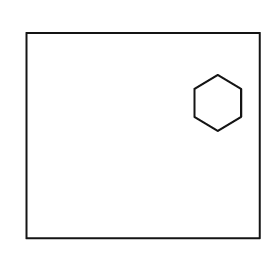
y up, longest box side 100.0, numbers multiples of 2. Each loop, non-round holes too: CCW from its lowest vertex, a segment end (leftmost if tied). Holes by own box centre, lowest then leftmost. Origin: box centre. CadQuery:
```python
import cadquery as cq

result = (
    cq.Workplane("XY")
    .moveTo(-50.0, -44.0)
    .lineTo(50.0, -44.0)
    .lineTo(50.0, 44.0)
    .lineTo(-50.0, 44.0)
    .close()
    .moveTo(32.0, 2.0)
    .lineTo(42.0, 8.0)
    .lineTo(42.0, 20.0)
    .lineTo(32.0, 26.0)
    .lineTo(22.0, 20.0)
    .lineTo(22.0, 8.0)
    .close()
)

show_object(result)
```